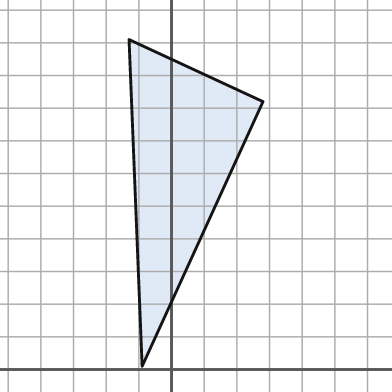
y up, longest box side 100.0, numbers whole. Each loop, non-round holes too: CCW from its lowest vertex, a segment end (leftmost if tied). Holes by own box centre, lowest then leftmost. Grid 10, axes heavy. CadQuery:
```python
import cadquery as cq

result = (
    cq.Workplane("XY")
    .moveTo(-9.0, 1.0)
    .lineTo(28.0, 82.0)
    .lineTo(-13.0, 101.0)
    .close()
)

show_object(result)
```